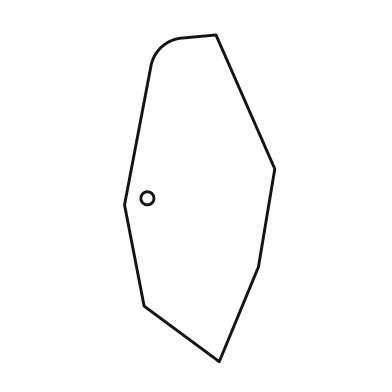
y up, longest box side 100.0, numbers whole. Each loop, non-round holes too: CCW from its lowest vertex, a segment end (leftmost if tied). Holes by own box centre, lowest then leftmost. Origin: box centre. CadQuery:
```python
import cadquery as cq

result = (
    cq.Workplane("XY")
    .moveTo(6.0, -50.0)
    .lineTo(18.0, -21.0)
    .lineTo(23.0, 9.0)
    .lineTo(5.0, 50.0)
    .lineTo(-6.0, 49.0)
    .threePointArc((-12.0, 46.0), (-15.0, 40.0))
    .lineTo(-23.0, -2.0)
    .lineTo(-17.0, -33.0)
    .close()
    .moveTo(-16.0, 0.0)
    .circle(2.0)
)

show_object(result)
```